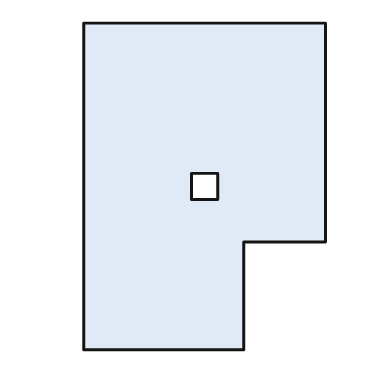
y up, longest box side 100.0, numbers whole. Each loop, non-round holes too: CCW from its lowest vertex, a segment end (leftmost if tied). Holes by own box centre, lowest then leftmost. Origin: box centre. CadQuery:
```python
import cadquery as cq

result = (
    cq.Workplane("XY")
    .moveTo(-37.0, -50.0)
    .lineTo(12.0, -50.0)
    .lineTo(12.0, -17.0)
    .lineTo(37.0, -17.0)
    .lineTo(37.0, 50.0)
    .lineTo(-37.0, 50.0)
    .close()
    .moveTo(-4.0, -4.0)
    .lineTo(4.0, -4.0)
    .lineTo(4.0, 4.0)
    .lineTo(-4.0, 4.0)
    .close()
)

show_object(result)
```